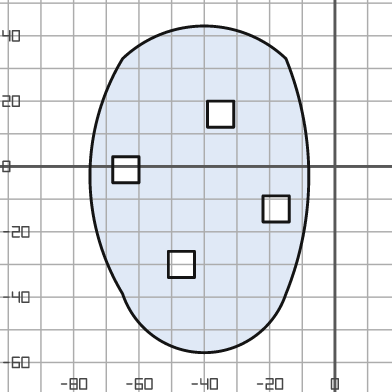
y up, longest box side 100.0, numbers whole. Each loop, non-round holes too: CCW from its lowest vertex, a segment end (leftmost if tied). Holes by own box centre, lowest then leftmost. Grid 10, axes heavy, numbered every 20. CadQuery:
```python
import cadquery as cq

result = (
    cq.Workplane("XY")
    .moveTo(-65.0, -39.0)
    .threePointArc((-40.0, -57.0), (-15.0, -39.0))
    .threePointArc((-8.0, -3.0), (-15.0, 33.0))
    .threePointArc((-40.0, 43.0), (-65.0, 33.0))
    .threePointArc((-75.0, -3.0), (-65.0, -39.0))
    .close()
    .moveTo(-51.0, -34.0)
    .lineTo(-43.0, -34.0)
    .lineTo(-43.0, -26.0)
    .lineTo(-51.0, -26.0)
    .close()
    .moveTo(-22.0, -17.0)
    .lineTo(-14.0, -17.0)
    .lineTo(-14.0, -9.0)
    .lineTo(-22.0, -9.0)
    .close()
    .moveTo(-68.0, -5.0)
    .lineTo(-60.0, -5.0)
    .lineTo(-60.0, 3.0)
    .lineTo(-68.0, 3.0)
    .close()
    .moveTo(-39.0, 12.0)
    .lineTo(-31.0, 12.0)
    .lineTo(-31.0, 20.0)
    .lineTo(-39.0, 20.0)
    .close()
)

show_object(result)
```